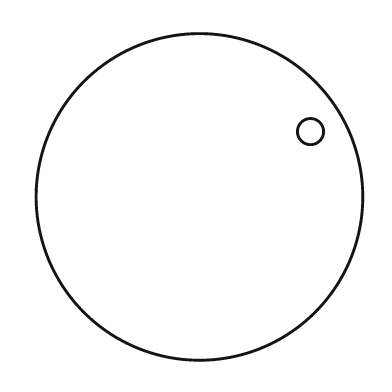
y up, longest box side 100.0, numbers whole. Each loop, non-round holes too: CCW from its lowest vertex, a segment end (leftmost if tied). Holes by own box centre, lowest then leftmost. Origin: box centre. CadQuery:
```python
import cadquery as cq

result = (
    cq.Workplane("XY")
    .moveTo(0.0, 0.0)
    .circle(50.0)
    .moveTo(34.0, 20.0)
    .circle(4.0)
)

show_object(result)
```